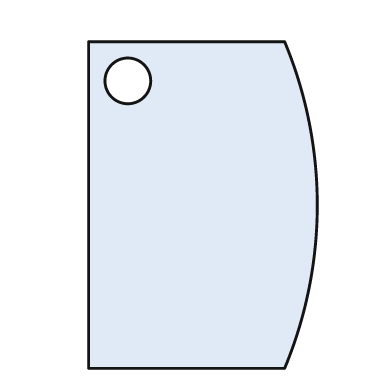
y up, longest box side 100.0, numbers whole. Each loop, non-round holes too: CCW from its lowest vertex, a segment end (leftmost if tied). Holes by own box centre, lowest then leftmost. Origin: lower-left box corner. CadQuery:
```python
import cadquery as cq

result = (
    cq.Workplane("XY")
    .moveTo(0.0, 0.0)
    .lineTo(60.0, 0.0)
    .threePointArc((70.0, 50.0), (60.0, 100.0))
    .lineTo(0.0, 100.0)
    .close()
    .moveTo(12.0, 88.0)
    .circle(7.0)
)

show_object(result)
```